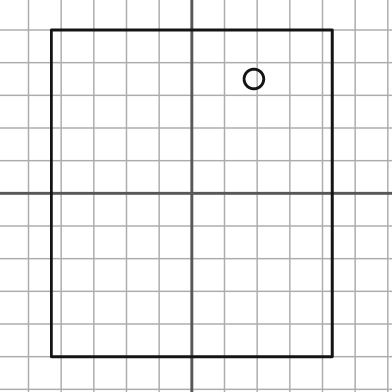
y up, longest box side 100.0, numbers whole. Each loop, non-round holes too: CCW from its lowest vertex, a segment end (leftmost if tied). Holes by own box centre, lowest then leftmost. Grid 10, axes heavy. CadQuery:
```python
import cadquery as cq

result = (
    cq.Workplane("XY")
    .moveTo(-43.0, -50.0)
    .lineTo(43.0, -50.0)
    .lineTo(43.0, 50.0)
    .lineTo(-43.0, 50.0)
    .close()
    .moveTo(19.0, 35.0)
    .circle(3.0)
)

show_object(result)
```